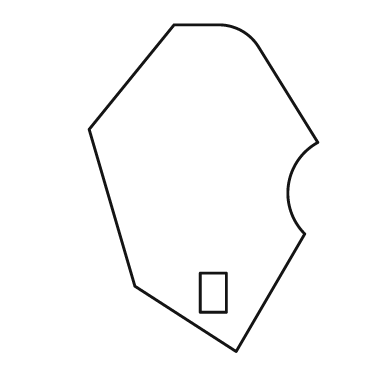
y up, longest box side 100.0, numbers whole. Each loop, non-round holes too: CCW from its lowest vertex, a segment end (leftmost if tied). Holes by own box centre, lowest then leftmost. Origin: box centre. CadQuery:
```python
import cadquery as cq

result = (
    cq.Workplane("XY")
    .moveTo(10.0, -50.0)
    .lineTo(31.0, -14.0)
    .threePointArc((26.0, 1.0), (35.0, 14.0))
    .lineTo(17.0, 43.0)
    .threePointArc((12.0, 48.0), (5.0, 50.0))
    .lineTo(-9.0, 50.0)
    .lineTo(-35.0, 18.0)
    .lineTo(-21.0, -30.0)
    .close()
    .moveTo(-1.0, -38.0)
    .lineTo(7.0, -38.0)
    .lineTo(7.0, -26.0)
    .lineTo(-1.0, -26.0)
    .close()
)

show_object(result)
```